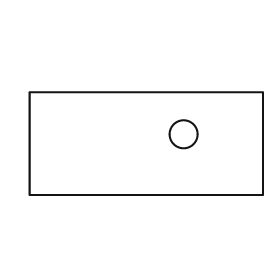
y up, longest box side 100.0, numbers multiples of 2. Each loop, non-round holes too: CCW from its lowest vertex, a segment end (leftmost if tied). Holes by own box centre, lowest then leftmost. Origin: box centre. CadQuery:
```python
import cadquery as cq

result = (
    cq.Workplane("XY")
    .moveTo(-50.0, -22.0)
    .lineTo(50.0, -22.0)
    .lineTo(50.0, 22.0)
    .lineTo(-50.0, 22.0)
    .close()
    .moveTo(16.0, 4.0)
    .circle(6.0)
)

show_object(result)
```